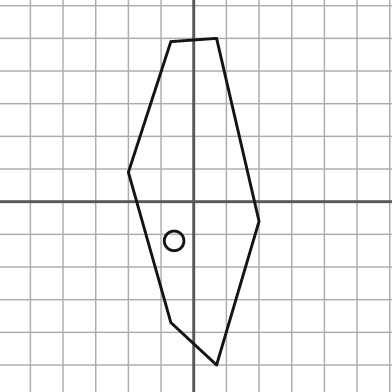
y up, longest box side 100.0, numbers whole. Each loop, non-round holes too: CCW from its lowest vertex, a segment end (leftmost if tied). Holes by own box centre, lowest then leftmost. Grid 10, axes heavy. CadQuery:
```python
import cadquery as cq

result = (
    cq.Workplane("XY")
    .moveTo(7.0, -50.0)
    .lineTo(20.0, -6.0)
    .lineTo(7.0, 50.0)
    .lineTo(-7.0, 49.0)
    .lineTo(-20.0, 9.0)
    .lineTo(-7.0, -37.0)
    .close()
    .moveTo(-6.0, -12.0)
    .circle(3.0)
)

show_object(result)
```